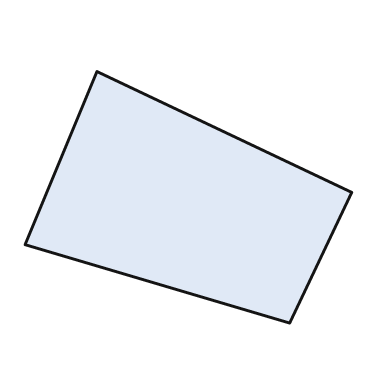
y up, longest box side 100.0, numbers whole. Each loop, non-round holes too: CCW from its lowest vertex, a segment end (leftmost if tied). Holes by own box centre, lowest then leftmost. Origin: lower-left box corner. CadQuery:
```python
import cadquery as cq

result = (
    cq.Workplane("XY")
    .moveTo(81.0, 0.0)
    .lineTo(100.0, 40.0)
    .lineTo(22.0, 77.0)
    .lineTo(0.0, 24.0)
    .close()
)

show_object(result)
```